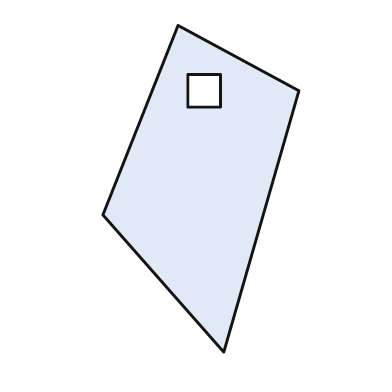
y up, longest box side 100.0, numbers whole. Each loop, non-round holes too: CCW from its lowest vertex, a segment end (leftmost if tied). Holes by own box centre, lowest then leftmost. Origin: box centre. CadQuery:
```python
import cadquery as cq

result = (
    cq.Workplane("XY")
    .moveTo(7.0, -50.0)
    .lineTo(30.0, 30.0)
    .lineTo(-7.0, 50.0)
    .lineTo(-30.0, -8.0)
    .close()
    .moveTo(-4.0, 25.0)
    .lineTo(6.0, 25.0)
    .lineTo(6.0, 35.0)
    .lineTo(-4.0, 35.0)
    .close()
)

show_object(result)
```